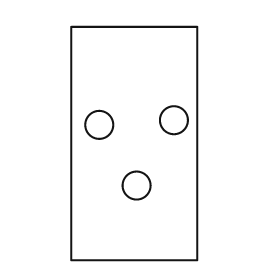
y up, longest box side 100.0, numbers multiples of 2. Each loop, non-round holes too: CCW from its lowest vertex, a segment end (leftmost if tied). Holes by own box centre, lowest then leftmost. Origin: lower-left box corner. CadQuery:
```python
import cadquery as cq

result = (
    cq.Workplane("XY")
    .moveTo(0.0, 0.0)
    .lineTo(54.0, 0.0)
    .lineTo(54.0, 100.0)
    .lineTo(0.0, 100.0)
    .close()
    .moveTo(28.0, 32.0)
    .circle(6.0)
    .moveTo(12.0, 58.0)
    .circle(6.0)
    .moveTo(44.0, 60.0)
    .circle(6.0)
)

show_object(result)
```